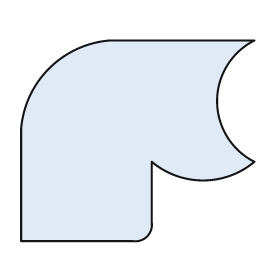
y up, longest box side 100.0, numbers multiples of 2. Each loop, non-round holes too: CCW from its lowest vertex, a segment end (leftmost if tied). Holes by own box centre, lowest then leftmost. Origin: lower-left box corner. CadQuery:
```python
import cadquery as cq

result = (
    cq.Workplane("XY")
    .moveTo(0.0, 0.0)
    .lineTo(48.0, 0.0)
    .threePointArc((54.0, 2.0), (56.0, 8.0))
    .lineTo(56.0, 34.0)
    .threePointArc((78.0, 26.0), (100.0, 34.0))
    .threePointArc((84.0, 60.0), (100.0, 86.0))
    .lineTo(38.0, 86.0)
    .threePointArc((12.0, 74.0), (0.0, 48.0))
    .close()
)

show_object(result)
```